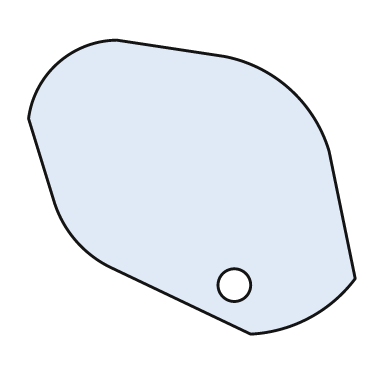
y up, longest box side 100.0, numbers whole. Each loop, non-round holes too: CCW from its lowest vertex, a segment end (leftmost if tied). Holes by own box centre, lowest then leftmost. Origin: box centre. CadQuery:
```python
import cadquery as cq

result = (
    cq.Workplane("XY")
    .moveTo(18.0, -45.0)
    .threePointArc((36.0, -40.0), (50.0, -28.0))
    .lineTo(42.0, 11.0)
    .threePointArc((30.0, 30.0), (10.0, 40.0))
    .lineTo(-23.0, 45.0)
    .threePointArc((-41.0, 38.0), (-50.0, 21.0))
    .lineTo(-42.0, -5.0)
    .threePointArc((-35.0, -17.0), (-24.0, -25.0))
    .close()
    .moveTo(13.0, -30.0)
    .circle(5.0)
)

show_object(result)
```